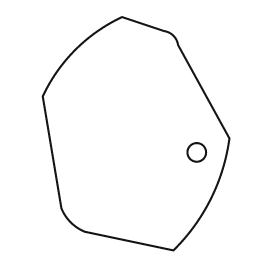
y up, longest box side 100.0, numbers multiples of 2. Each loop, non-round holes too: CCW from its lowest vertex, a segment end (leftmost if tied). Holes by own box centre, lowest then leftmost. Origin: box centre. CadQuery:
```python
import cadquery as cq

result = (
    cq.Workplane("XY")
    .moveTo(16.0, -50.0)
    .threePointArc((32.0, -28.0), (40.0, -2.0))
    .lineTo(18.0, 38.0)
    .threePointArc((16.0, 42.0), (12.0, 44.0))
    .lineTo(-6.0, 50.0)
    .threePointArc((-26.0, 36.0), (-40.0, 16.0))
    .lineTo(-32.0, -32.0)
    .threePointArc((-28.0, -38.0), (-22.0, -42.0))
    .close()
    .moveTo(26.0, -8.0)
    .circle(4.0)
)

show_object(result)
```